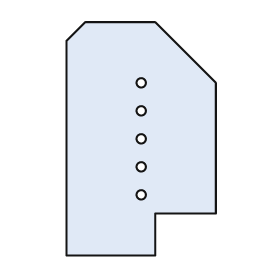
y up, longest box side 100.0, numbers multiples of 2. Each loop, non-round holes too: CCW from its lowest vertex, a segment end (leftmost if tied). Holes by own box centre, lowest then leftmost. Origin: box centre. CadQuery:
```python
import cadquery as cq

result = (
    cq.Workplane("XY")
    .moveTo(-32.0, -50.0)
    .lineTo(6.0, -50.0)
    .lineTo(6.0, -32.0)
    .lineTo(32.0, -32.0)
    .lineTo(32.0, 24.0)
    .lineTo(6.0, 50.0)
    .lineTo(-24.0, 50.0)
    .lineTo(-32.0, 42.0)
    .close()
    .moveTo(0.0, -24.0)
    .circle(2.0)
    .moveTo(0.0, -12.0)
    .circle(2.0)
    .moveTo(0.0, 0.0)
    .circle(2.0)
    .moveTo(0.0, 12.0)
    .circle(2.0)
    .moveTo(0.0, 24.0)
    .circle(2.0)
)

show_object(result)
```